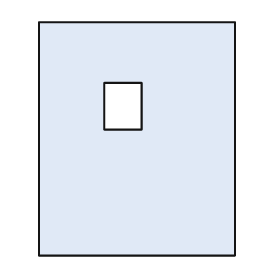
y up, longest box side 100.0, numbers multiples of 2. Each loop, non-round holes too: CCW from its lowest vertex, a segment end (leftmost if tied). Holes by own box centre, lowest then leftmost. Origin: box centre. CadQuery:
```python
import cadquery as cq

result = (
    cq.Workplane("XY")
    .moveTo(-42.0, -50.0)
    .lineTo(42.0, -50.0)
    .lineTo(42.0, 50.0)
    .lineTo(-42.0, 50.0)
    .close()
    .moveTo(-14.0, 4.0)
    .lineTo(2.0, 4.0)
    .lineTo(2.0, 24.0)
    .lineTo(-14.0, 24.0)
    .close()
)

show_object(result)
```